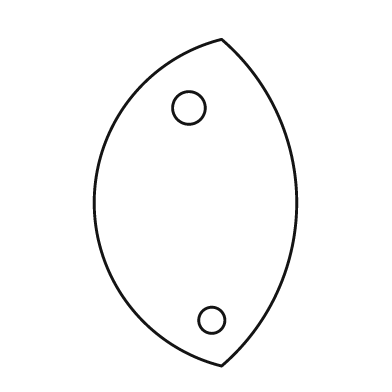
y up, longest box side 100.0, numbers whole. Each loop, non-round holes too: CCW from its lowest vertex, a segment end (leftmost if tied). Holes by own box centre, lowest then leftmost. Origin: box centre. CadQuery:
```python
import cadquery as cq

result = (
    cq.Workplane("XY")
    .moveTo(8.0, -50.0)
    .threePointArc((31.0, 0.0), (8.0, 50.0))
    .threePointArc((-31.0, 0.0), (8.0, -50.0))
    .close()
    .moveTo(5.0, -36.0)
    .circle(4.0)
    .moveTo(-2.0, 29.0)
    .circle(5.0)
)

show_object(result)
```